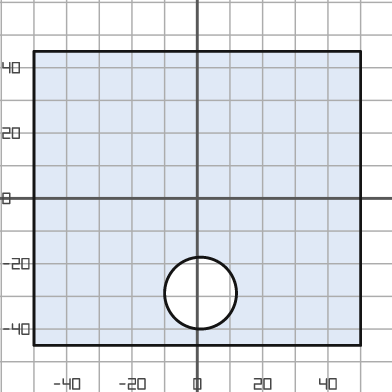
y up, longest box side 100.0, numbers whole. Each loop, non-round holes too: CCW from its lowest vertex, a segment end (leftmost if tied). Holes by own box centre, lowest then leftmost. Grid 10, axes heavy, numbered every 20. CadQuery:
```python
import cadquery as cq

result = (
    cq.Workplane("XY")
    .moveTo(-50.0, -45.0)
    .lineTo(50.0, -45.0)
    .lineTo(50.0, 45.0)
    .lineTo(-50.0, 45.0)
    .close()
    .moveTo(1.0, -29.0)
    .circle(11.0)
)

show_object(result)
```